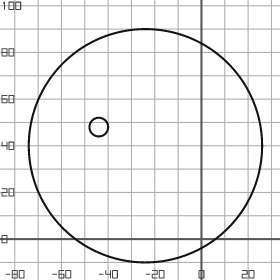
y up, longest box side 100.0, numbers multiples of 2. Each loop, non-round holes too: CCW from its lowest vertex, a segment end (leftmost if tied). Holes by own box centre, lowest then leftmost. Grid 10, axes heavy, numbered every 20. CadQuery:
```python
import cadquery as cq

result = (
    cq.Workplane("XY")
    .moveTo(-24.0, 40.0)
    .circle(50.0)
    .moveTo(-44.0, 48.0)
    .circle(4.0)
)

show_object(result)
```